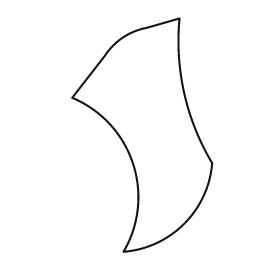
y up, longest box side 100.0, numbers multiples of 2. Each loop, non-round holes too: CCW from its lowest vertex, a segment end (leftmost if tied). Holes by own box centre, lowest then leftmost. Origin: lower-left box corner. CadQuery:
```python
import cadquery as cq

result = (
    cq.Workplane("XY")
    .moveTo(22.0, 0.0)
    .threePointArc((48.0, 12.0), (60.0, 38.0))
    .threePointArc((48.0, 68.0), (46.0, 100.0))
    .lineTo(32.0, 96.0)
    .threePointArc((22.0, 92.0), (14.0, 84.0))
    .lineTo(0.0, 66.0)
    .threePointArc((26.0, 38.0), (22.0, 0.0))
    .close()
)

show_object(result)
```